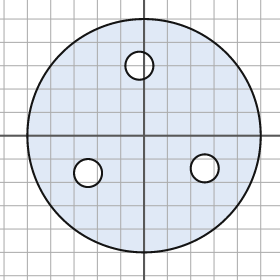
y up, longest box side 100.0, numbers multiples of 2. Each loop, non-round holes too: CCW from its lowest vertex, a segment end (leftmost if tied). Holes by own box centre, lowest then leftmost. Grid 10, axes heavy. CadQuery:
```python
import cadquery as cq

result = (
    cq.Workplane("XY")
    .moveTo(0.0, 0.0)
    .circle(50.0)
    .moveTo(-24.0, -16.0)
    .circle(6.0)
    .moveTo(26.0, -14.0)
    .circle(6.0)
    .moveTo(-2.0, 30.0)
    .circle(6.0)
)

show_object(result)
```